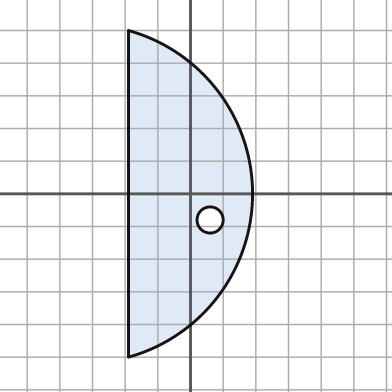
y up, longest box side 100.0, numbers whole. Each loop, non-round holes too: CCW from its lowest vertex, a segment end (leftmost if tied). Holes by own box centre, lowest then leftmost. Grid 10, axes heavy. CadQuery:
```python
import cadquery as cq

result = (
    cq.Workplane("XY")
    .moveTo(-19.0, -50.0)
    .threePointArc((19.0, 0.0), (-19.0, 50.0))
    .close()
    .moveTo(6.0, -8.0)
    .circle(4.0)
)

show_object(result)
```